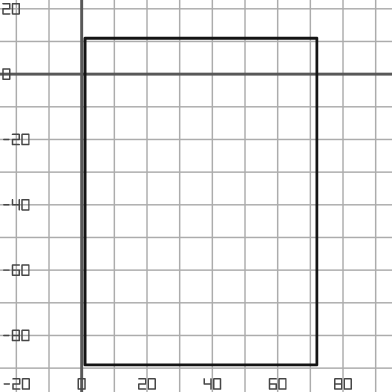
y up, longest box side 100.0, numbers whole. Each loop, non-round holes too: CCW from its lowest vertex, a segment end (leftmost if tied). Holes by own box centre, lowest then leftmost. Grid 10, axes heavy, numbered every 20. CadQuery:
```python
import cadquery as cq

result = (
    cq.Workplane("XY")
    .moveTo(1.0, -89.0)
    .lineTo(72.0, -89.0)
    .lineTo(72.0, 11.0)
    .lineTo(1.0, 11.0)
    .close()
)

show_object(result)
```